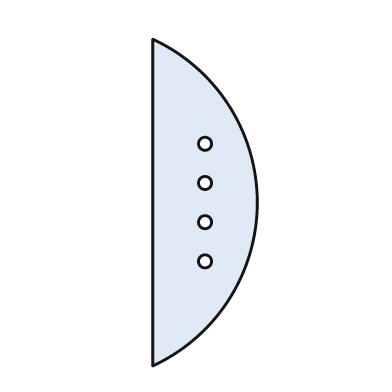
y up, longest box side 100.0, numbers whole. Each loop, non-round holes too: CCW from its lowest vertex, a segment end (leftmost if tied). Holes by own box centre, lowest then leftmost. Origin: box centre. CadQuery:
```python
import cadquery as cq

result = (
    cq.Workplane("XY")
    .moveTo(-16.0, -50.0)
    .threePointArc((16.0, 0.0), (-16.0, 50.0))
    .close()
    .moveTo(0.0, -18.0)
    .circle(2.0)
    .moveTo(0.0, -6.0)
    .circle(2.0)
    .moveTo(0.0, 6.0)
    .circle(2.0)
    .moveTo(0.0, 18.0)
    .circle(2.0)
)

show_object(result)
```